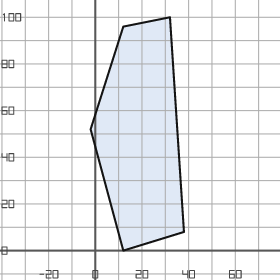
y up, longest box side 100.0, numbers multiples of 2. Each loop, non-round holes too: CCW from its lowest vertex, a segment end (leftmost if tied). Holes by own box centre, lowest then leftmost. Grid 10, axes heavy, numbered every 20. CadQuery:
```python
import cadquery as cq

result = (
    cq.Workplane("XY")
    .moveTo(12.0, 0.0)
    .lineTo(38.0, 8.0)
    .lineTo(32.0, 100.0)
    .lineTo(12.0, 96.0)
    .lineTo(-2.0, 52.0)
    .close()
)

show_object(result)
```